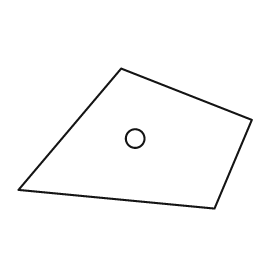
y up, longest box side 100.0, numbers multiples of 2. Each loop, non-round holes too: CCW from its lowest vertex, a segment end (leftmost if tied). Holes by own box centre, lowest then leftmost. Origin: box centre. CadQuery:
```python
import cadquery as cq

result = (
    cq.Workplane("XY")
    .moveTo(34.0, -30.0)
    .lineTo(50.0, 8.0)
    .lineTo(-6.0, 30.0)
    .lineTo(-50.0, -22.0)
    .close()
    .moveTo(0.0, 0.0)
    .circle(4.0)
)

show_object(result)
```